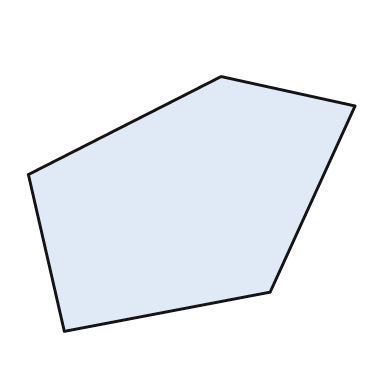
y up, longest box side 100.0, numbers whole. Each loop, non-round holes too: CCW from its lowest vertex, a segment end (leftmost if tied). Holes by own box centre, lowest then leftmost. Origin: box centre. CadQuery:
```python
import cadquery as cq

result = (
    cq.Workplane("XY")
    .moveTo(-39.0, -39.0)
    .lineTo(24.0, -27.0)
    .lineTo(50.0, 30.0)
    .lineTo(9.0, 39.0)
    .lineTo(-50.0, 9.0)
    .close()
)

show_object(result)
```